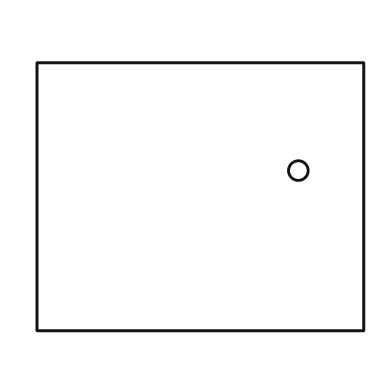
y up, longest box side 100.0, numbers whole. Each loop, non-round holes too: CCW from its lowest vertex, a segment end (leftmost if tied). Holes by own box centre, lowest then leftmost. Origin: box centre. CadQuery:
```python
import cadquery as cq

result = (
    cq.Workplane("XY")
    .moveTo(-50.0, -41.0)
    .lineTo(50.0, -41.0)
    .lineTo(50.0, 41.0)
    .lineTo(-50.0, 41.0)
    .close()
    .moveTo(30.0, 8.0)
    .circle(3.0)
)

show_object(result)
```